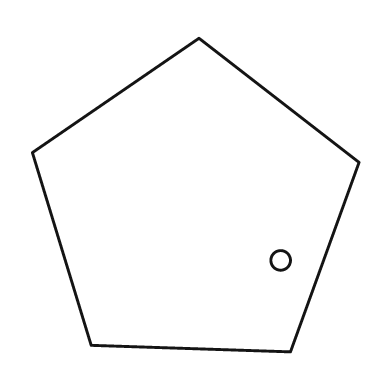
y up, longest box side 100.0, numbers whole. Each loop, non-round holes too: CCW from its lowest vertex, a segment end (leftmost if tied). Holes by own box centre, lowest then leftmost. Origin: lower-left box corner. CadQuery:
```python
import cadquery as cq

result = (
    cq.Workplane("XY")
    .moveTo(79.0, 0.0)
    .lineTo(100.0, 58.0)
    .lineTo(51.0, 96.0)
    .lineTo(0.0, 61.0)
    .lineTo(18.0, 2.0)
    .close()
    .moveTo(76.0, 28.0)
    .circle(3.0)
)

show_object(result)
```